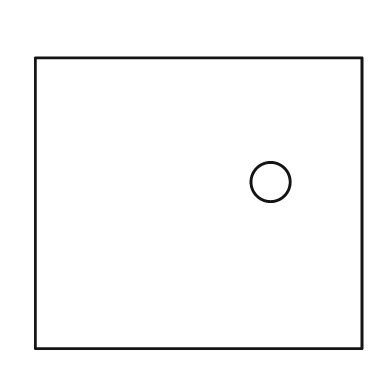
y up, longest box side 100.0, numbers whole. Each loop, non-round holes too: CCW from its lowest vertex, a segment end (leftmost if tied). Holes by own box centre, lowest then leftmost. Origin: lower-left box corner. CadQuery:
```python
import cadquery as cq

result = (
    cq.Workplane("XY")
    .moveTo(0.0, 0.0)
    .lineTo(100.0, 0.0)
    .lineTo(100.0, 89.0)
    .lineTo(0.0, 89.0)
    .close()
    .moveTo(72.0, 51.0)
    .circle(6.0)
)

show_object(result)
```